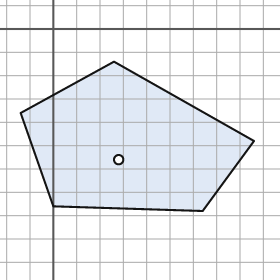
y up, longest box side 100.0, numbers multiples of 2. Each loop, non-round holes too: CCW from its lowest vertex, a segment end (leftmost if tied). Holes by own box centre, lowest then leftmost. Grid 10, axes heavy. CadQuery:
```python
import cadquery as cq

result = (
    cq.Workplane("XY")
    .moveTo(64.0, -78.0)
    .lineTo(86.0, -48.0)
    .lineTo(26.0, -14.0)
    .lineTo(-14.0, -36.0)
    .lineTo(0.0, -76.0)
    .close()
    .moveTo(28.0, -56.0)
    .circle(2.0)
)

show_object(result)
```